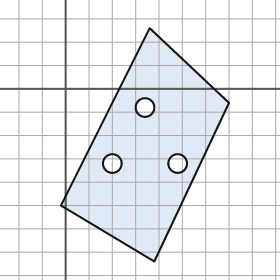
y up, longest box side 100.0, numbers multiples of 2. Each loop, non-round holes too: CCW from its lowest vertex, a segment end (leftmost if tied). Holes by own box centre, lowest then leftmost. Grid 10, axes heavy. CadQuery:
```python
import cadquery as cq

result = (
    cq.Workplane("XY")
    .moveTo(38.0, -74.0)
    .lineTo(70.0, -6.0)
    .lineTo(36.0, 26.0)
    .lineTo(-2.0, -50.0)
    .close()
    .moveTo(20.0, -32.0)
    .circle(4.0)
    .moveTo(48.0, -32.0)
    .circle(4.0)
    .moveTo(34.0, -8.0)
    .circle(4.0)
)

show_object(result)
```